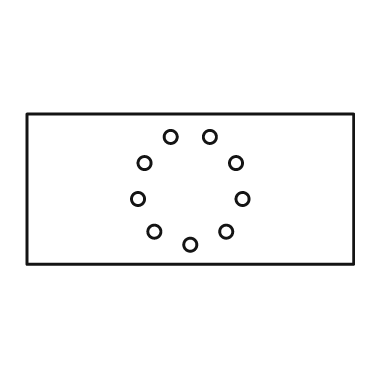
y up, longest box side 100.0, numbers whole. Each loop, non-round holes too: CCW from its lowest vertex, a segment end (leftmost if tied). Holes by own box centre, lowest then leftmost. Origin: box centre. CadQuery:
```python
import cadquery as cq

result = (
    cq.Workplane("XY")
    .moveTo(-50.0, -23.0)
    .lineTo(50.0, -23.0)
    .lineTo(50.0, 23.0)
    .lineTo(-50.0, 23.0)
    .close()
    .moveTo(0.0, -17.0)
    .circle(2.0)
    .moveTo(-11.0, -13.0)
    .circle(2.0)
    .moveTo(11.0, -13.0)
    .circle(2.0)
    .moveTo(-16.0, -3.0)
    .circle(2.0)
    .moveTo(16.0, -3.0)
    .circle(2.0)
    .moveTo(-14.0, 8.0)
    .circle(2.0)
    .moveTo(14.0, 8.0)
    .circle(2.0)
    .moveTo(-6.0, 16.0)
    .circle(2.0)
    .moveTo(6.0, 16.0)
    .circle(2.0)
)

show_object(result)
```